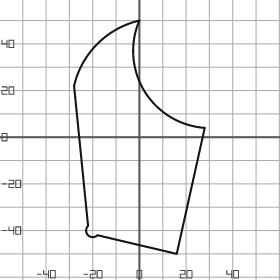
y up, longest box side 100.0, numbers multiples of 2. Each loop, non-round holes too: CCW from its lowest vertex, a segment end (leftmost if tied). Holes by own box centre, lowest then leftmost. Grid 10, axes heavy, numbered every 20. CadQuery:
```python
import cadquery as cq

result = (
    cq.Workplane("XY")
    .moveTo(16.0, -50.0)
    .lineTo(28.0, 4.0)
    .threePointArc((2.0, 20.0), (0.0, 50.0))
    .threePointArc((-18.0, 40.0), (-28.0, 22.0))
    .lineTo(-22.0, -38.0)
    .threePointArc((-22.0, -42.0), (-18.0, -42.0))
    .close()
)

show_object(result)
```